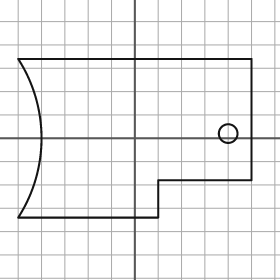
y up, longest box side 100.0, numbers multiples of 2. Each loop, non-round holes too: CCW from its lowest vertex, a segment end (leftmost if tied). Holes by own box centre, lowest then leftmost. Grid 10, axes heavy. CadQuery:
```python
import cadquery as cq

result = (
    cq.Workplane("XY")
    .moveTo(-50.0, -34.0)
    .lineTo(10.0, -34.0)
    .lineTo(10.0, -18.0)
    .lineTo(50.0, -18.0)
    .lineTo(50.0, 34.0)
    .lineTo(-50.0, 34.0)
    .threePointArc((-40.0, 0.0), (-50.0, -34.0))
    .close()
    .moveTo(40.0, 2.0)
    .circle(4.0)
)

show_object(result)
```